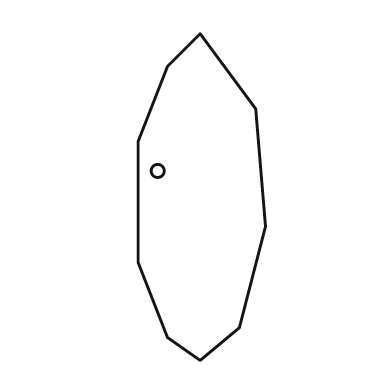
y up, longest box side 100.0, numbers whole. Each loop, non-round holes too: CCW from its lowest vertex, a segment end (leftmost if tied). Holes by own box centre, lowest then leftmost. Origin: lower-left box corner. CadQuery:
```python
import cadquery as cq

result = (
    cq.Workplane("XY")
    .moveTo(19.0, 0.0)
    .lineTo(31.0, 10.0)
    .lineTo(39.0, 41.0)
    .lineTo(36.0, 77.0)
    .lineTo(19.0, 100.0)
    .lineTo(9.0, 90.0)
    .lineTo(0.0, 67.0)
    .lineTo(0.0, 30.0)
    .lineTo(9.0, 7.0)
    .close()
    .moveTo(6.0, 58.0)
    .circle(2.0)
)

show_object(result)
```